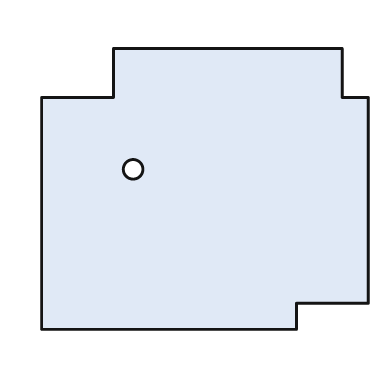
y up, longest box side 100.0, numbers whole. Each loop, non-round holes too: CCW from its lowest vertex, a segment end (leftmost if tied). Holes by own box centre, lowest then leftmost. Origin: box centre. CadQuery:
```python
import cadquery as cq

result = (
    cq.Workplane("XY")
    .moveTo(-50.0, -43.0)
    .lineTo(28.0, -43.0)
    .lineTo(28.0, -35.0)
    .lineTo(50.0, -35.0)
    .lineTo(50.0, 28.0)
    .lineTo(42.0, 28.0)
    .lineTo(42.0, 43.0)
    .lineTo(-28.0, 43.0)
    .lineTo(-28.0, 28.0)
    .lineTo(-50.0, 28.0)
    .close()
    .moveTo(-22.0, 6.0)
    .circle(3.0)
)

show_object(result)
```